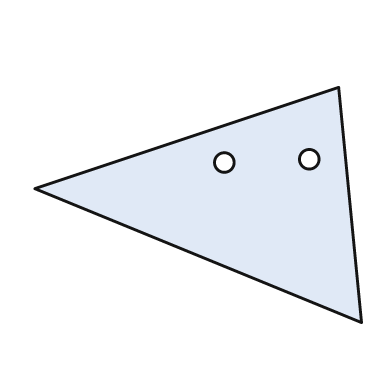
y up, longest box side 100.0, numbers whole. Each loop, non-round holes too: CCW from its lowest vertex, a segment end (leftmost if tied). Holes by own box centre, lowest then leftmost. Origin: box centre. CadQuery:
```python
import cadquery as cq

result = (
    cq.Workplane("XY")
    .moveTo(50.0, -36.0)
    .lineTo(43.0, 36.0)
    .lineTo(-50.0, 5.0)
    .close()
    .moveTo(8.0, 13.0)
    .circle(3.0)
    .moveTo(34.0, 14.0)
    .circle(3.0)
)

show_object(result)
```